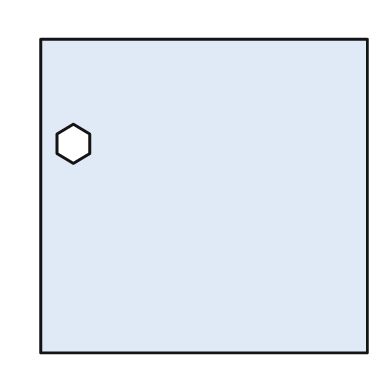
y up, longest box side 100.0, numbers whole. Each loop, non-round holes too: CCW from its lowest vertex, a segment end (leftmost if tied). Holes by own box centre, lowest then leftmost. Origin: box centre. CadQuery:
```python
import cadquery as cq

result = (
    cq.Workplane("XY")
    .moveTo(-50.0, -48.0)
    .lineTo(50.0, -48.0)
    .lineTo(50.0, 48.0)
    .lineTo(-50.0, 48.0)
    .close()
    .moveTo(-40.0, 10.0)
    .lineTo(-35.0, 13.0)
    .lineTo(-35.0, 19.0)
    .lineTo(-40.0, 22.0)
    .lineTo(-45.0, 19.0)
    .lineTo(-45.0, 13.0)
    .close()
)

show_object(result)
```